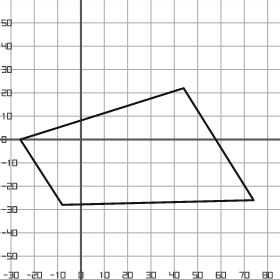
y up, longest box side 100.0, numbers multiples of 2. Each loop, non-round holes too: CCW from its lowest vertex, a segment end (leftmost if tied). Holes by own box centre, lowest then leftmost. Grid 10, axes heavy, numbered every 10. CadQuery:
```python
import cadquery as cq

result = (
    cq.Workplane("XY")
    .moveTo(-8.0, -28.0)
    .lineTo(74.0, -26.0)
    .lineTo(44.0, 22.0)
    .lineTo(-26.0, 0.0)
    .close()
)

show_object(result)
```